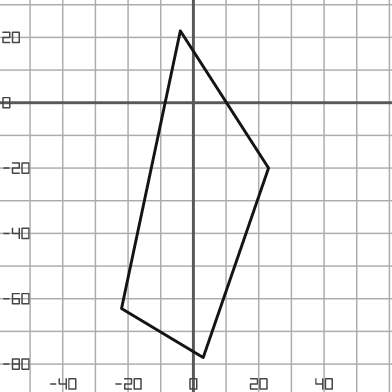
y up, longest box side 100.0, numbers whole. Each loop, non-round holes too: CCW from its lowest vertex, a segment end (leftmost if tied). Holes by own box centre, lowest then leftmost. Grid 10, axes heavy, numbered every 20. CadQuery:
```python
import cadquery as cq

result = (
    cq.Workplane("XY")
    .moveTo(3.0, -78.0)
    .lineTo(23.0, -20.0)
    .lineTo(-4.0, 22.0)
    .lineTo(-22.0, -63.0)
    .close()
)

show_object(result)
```